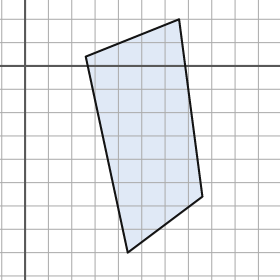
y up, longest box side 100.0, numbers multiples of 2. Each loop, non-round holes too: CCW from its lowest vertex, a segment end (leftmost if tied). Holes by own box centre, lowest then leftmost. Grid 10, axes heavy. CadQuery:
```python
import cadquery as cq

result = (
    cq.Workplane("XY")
    .moveTo(44.0, -80.0)
    .lineTo(76.0, -56.0)
    .lineTo(66.0, 20.0)
    .lineTo(26.0, 4.0)
    .close()
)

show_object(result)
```